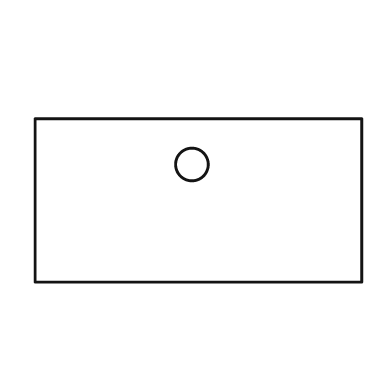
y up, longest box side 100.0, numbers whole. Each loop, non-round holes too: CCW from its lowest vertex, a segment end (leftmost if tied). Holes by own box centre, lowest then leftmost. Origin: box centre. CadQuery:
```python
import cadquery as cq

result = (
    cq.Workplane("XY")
    .moveTo(-50.0, -25.0)
    .lineTo(50.0, -25.0)
    .lineTo(50.0, 25.0)
    .lineTo(-50.0, 25.0)
    .close()
    .moveTo(-2.0, 11.0)
    .circle(5.0)
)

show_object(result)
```